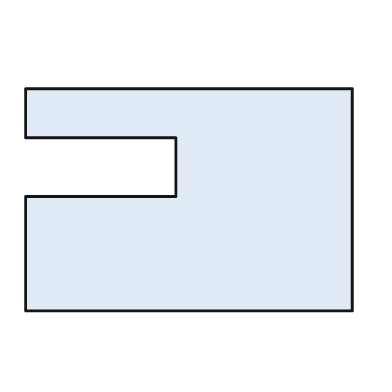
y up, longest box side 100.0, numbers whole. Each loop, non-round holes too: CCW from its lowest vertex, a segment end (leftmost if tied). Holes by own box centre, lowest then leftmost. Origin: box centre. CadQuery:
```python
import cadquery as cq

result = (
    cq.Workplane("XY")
    .moveTo(-50.0, -34.0)
    .lineTo(50.0, -34.0)
    .lineTo(50.0, 34.0)
    .lineTo(-50.0, 34.0)
    .lineTo(-50.0, 19.0)
    .lineTo(-4.0, 19.0)
    .lineTo(-4.0, 1.0)
    .lineTo(-50.0, 1.0)
    .close()
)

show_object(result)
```